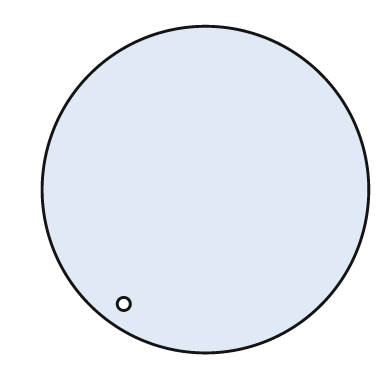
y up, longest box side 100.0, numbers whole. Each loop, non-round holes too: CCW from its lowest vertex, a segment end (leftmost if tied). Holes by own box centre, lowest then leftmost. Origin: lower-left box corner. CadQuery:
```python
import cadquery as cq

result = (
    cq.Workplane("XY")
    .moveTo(50.0, 50.0)
    .circle(50.0)
    .moveTo(25.0, 15.0)
    .circle(2.0)
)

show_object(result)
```